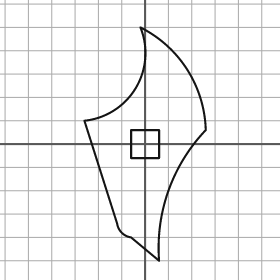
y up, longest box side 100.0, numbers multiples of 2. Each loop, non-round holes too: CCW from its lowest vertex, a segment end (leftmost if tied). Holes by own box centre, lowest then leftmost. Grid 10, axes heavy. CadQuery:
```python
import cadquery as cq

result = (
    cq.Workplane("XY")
    .moveTo(6.0, -50.0)
    .threePointArc((10.0, -20.0), (26.0, 6.0))
    .threePointArc((18.0, 32.0), (-2.0, 50.0))
    .threePointArc((-4.0, 24.0), (-26.0, 10.0))
    .lineTo(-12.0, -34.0)
    .threePointArc((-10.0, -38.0), (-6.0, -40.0))
    .close()
    .moveTo(-6.0, -6.0)
    .lineTo(6.0, -6.0)
    .lineTo(6.0, 6.0)
    .lineTo(-6.0, 6.0)
    .close()
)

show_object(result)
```